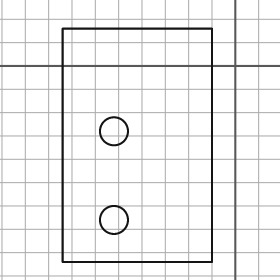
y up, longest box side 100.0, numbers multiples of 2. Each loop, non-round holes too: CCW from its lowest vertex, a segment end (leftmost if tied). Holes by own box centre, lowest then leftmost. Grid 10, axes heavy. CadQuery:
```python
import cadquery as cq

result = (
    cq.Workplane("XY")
    .moveTo(-74.0, -84.0)
    .lineTo(-10.0, -84.0)
    .lineTo(-10.0, 16.0)
    .lineTo(-74.0, 16.0)
    .close()
    .moveTo(-52.0, -66.0)
    .circle(6.0)
    .moveTo(-52.0, -28.0)
    .circle(6.0)
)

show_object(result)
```